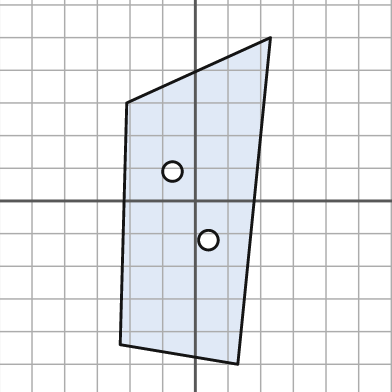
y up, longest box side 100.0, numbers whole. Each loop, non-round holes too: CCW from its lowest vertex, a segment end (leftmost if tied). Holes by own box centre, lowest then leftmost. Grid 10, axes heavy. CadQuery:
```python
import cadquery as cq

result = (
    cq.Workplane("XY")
    .moveTo(13.0, -50.0)
    .lineTo(23.0, 50.0)
    .lineTo(-21.0, 30.0)
    .lineTo(-23.0, -44.0)
    .close()
    .moveTo(4.0, -12.0)
    .circle(3.0)
    .moveTo(-7.0, 9.0)
    .circle(3.0)
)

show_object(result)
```